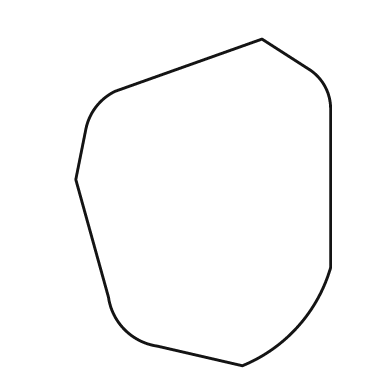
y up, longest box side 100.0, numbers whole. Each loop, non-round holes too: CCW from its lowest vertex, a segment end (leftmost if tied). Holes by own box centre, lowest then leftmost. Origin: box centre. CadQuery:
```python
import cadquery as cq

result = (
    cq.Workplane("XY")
    .moveTo(12.0, -50.0)
    .threePointArc((29.0, -38.0), (39.0, -20.0))
    .lineTo(39.0, 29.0)
    .threePointArc((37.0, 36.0), (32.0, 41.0))
    .lineTo(18.0, 50.0)
    .lineTo(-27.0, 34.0)
    .threePointArc((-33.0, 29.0), (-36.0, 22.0))
    .lineTo(-39.0, 7.0)
    .lineTo(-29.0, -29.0)
    .threePointArc((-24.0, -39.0), (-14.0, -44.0))
    .close()
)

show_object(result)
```